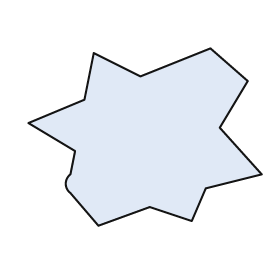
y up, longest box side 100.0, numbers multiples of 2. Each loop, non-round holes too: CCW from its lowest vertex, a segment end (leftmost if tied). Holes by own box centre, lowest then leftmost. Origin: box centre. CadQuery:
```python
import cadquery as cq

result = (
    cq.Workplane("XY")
    .moveTo(-20.0, -38.0)
    .lineTo(2.0, -30.0)
    .lineTo(20.0, -36.0)
    .lineTo(26.0, -22.0)
    .lineTo(50.0, -16.0)
    .lineTo(32.0, 4.0)
    .lineTo(44.0, 24.0)
    .lineTo(28.0, 38.0)
    .lineTo(-2.0, 26.0)
    .lineTo(-22.0, 36.0)
    .lineTo(-26.0, 16.0)
    .lineTo(-50.0, 6.0)
    .lineTo(-30.0, -6.0)
    .lineTo(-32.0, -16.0)
    .threePointArc((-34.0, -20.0), (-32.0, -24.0))
    .close()
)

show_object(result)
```